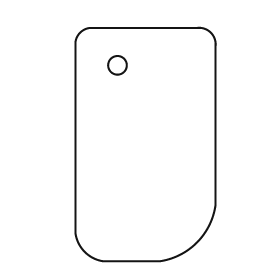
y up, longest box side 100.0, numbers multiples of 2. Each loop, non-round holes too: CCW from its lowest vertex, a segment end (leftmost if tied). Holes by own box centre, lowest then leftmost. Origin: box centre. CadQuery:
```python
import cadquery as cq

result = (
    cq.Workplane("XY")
    .moveTo(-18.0, -50.0)
    .lineTo(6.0, -50.0)
    .threePointArc((22.0, -42.0), (30.0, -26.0))
    .lineTo(30.0, 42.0)
    .threePointArc((28.0, 48.0), (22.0, 50.0))
    .lineTo(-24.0, 50.0)
    .threePointArc((-28.0, 48.0), (-30.0, 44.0))
    .lineTo(-30.0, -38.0)
    .threePointArc((-26.0, -46.0), (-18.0, -50.0))
    .close()
    .moveTo(-12.0, 34.0)
    .circle(4.0)
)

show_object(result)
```